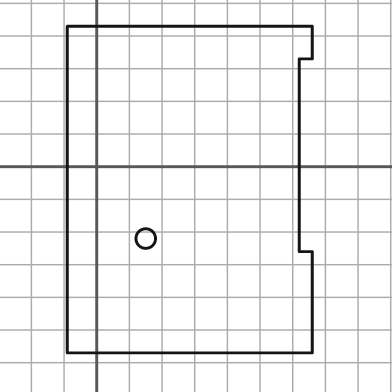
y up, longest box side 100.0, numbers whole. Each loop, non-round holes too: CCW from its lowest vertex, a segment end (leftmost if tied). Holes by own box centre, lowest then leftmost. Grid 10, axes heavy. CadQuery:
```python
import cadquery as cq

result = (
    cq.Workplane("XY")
    .moveTo(-9.0, -57.0)
    .lineTo(66.0, -57.0)
    .lineTo(66.0, -26.0)
    .lineTo(62.0, -26.0)
    .lineTo(62.0, 33.0)
    .lineTo(66.0, 33.0)
    .lineTo(66.0, 43.0)
    .lineTo(-9.0, 43.0)
    .close()
    .moveTo(15.0, -22.0)
    .circle(3.0)
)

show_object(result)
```